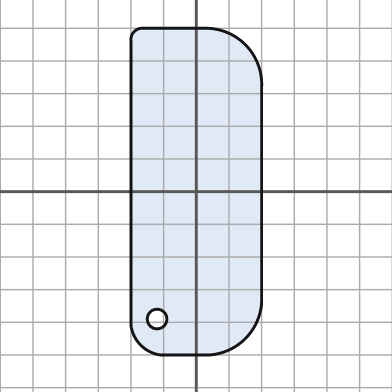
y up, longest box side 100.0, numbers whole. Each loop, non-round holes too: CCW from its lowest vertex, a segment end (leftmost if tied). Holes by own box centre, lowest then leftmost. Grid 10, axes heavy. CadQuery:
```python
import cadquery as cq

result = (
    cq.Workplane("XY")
    .moveTo(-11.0, -50.0)
    .lineTo(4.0, -50.0)
    .threePointArc((15.0, -45.0), (20.0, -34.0))
    .lineTo(20.0, 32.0)
    .threePointArc((15.0, 45.0), (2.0, 50.0))
    .lineTo(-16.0, 50.0)
    .threePointArc((-19.0, 49.0), (-20.0, 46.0))
    .lineTo(-20.0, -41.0)
    .threePointArc((-17.0, -47.0), (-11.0, -50.0))
    .close()
    .moveTo(-12.0, -39.0)
    .circle(3.0)
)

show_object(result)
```